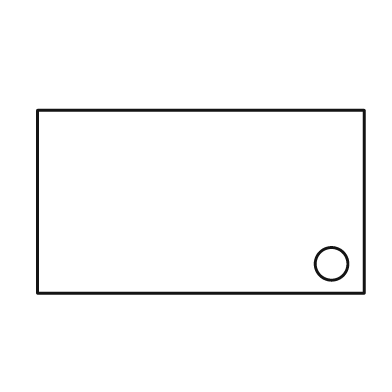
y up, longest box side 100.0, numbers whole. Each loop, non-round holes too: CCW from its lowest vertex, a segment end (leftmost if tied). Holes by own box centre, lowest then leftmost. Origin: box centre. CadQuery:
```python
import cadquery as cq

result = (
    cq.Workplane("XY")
    .moveTo(-50.0, -28.0)
    .lineTo(50.0, -28.0)
    .lineTo(50.0, 28.0)
    .lineTo(-50.0, 28.0)
    .close()
    .moveTo(40.0, -19.0)
    .circle(5.0)
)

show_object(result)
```